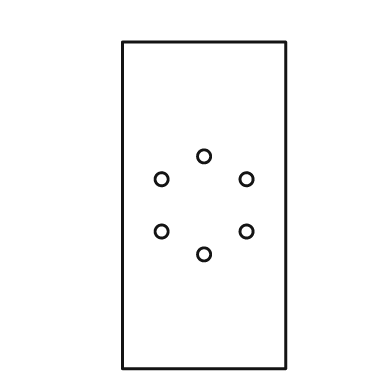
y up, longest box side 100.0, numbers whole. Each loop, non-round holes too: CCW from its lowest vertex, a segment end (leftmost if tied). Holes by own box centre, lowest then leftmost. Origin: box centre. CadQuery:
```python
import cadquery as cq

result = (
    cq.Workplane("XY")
    .moveTo(-25.0, -50.0)
    .lineTo(25.0, -50.0)
    .lineTo(25.0, 50.0)
    .lineTo(-25.0, 50.0)
    .close()
    .moveTo(0.0, -15.0)
    .circle(2.0)
    .moveTo(-13.0, -8.0)
    .circle(2.0)
    .moveTo(13.0, -8.0)
    .circle(2.0)
    .moveTo(-13.0, 8.0)
    .circle(2.0)
    .moveTo(13.0, 8.0)
    .circle(2.0)
    .moveTo(0.0, 15.0)
    .circle(2.0)
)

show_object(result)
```